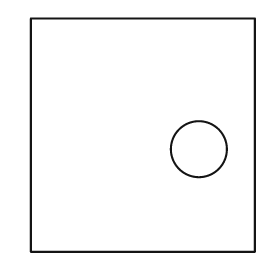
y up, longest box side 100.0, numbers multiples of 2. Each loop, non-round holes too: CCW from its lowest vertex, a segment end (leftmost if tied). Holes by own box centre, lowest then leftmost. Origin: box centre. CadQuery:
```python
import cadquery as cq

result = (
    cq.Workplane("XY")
    .moveTo(-48.0, -50.0)
    .lineTo(48.0, -50.0)
    .lineTo(48.0, 50.0)
    .lineTo(-48.0, 50.0)
    .close()
    .moveTo(24.0, -6.0)
    .circle(12.0)
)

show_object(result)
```